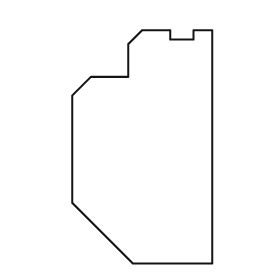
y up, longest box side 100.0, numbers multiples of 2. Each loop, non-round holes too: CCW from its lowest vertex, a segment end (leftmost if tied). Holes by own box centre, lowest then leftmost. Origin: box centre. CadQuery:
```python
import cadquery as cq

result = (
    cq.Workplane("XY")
    .moveTo(-4.0, -50.0)
    .lineTo(30.0, -50.0)
    .lineTo(30.0, 50.0)
    .lineTo(22.0, 50.0)
    .lineTo(22.0, 46.0)
    .lineTo(12.0, 46.0)
    .lineTo(12.0, 50.0)
    .lineTo(0.0, 50.0)
    .lineTo(-6.0, 44.0)
    .lineTo(-6.0, 30.0)
    .lineTo(-22.0, 30.0)
    .lineTo(-30.0, 22.0)
    .lineTo(-30.0, -24.0)
    .close()
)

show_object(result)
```